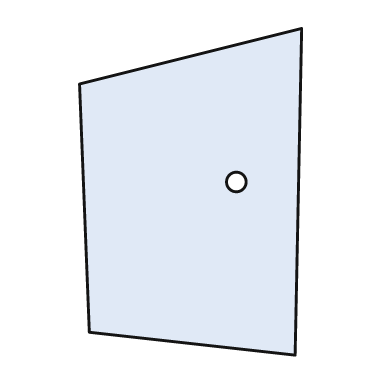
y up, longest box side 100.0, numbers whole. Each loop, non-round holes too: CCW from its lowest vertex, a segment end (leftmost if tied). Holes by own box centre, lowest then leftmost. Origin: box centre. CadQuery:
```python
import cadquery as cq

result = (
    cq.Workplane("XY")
    .moveTo(32.0, -50.0)
    .lineTo(34.0, 50.0)
    .lineTo(-34.0, 33.0)
    .lineTo(-31.0, -43.0)
    .close()
    .moveTo(14.0, 3.0)
    .circle(3.0)
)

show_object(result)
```